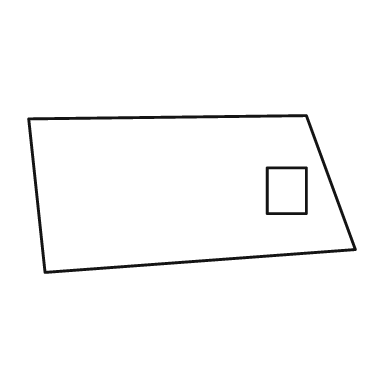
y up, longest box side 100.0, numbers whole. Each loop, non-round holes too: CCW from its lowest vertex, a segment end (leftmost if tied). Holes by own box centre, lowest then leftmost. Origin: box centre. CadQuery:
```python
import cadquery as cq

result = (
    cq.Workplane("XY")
    .moveTo(-45.0, -24.0)
    .lineTo(50.0, -17.0)
    .lineTo(35.0, 24.0)
    .lineTo(-50.0, 23.0)
    .close()
    .moveTo(23.0, -6.0)
    .lineTo(35.0, -6.0)
    .lineTo(35.0, 8.0)
    .lineTo(23.0, 8.0)
    .close()
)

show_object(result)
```